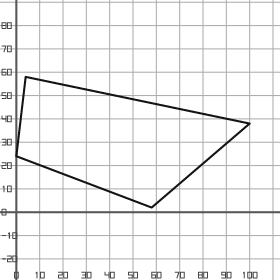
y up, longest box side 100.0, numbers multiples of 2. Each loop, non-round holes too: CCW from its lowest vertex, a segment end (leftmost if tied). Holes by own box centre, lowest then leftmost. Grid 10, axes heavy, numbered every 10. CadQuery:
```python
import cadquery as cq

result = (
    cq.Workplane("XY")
    .moveTo(58.0, 2.0)
    .lineTo(100.0, 38.0)
    .lineTo(4.0, 58.0)
    .lineTo(0.0, 24.0)
    .close()
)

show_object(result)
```